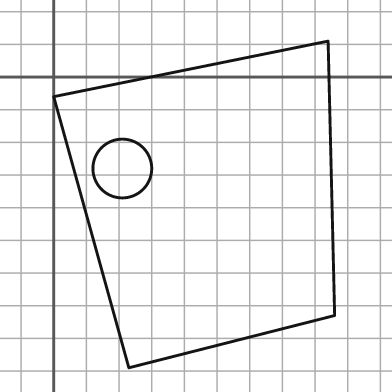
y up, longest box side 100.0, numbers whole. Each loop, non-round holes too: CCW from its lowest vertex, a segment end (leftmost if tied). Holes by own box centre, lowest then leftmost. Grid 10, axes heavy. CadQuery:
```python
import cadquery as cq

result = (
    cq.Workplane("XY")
    .moveTo(23.0, -89.0)
    .lineTo(86.0, -73.0)
    .lineTo(84.0, 11.0)
    .lineTo(0.0, -6.0)
    .close()
    .moveTo(21.0, -28.0)
    .circle(9.0)
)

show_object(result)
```